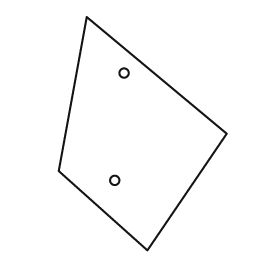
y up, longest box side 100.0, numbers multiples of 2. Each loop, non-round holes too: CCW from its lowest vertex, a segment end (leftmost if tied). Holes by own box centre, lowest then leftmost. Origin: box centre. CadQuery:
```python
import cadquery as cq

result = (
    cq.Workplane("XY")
    .moveTo(2.0, -50.0)
    .lineTo(36.0, 0.0)
    .lineTo(-24.0, 50.0)
    .lineTo(-36.0, -16.0)
    .close()
    .moveTo(-12.0, -20.0)
    .circle(2.0)
    .moveTo(-8.0, 26.0)
    .circle(2.0)
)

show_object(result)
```